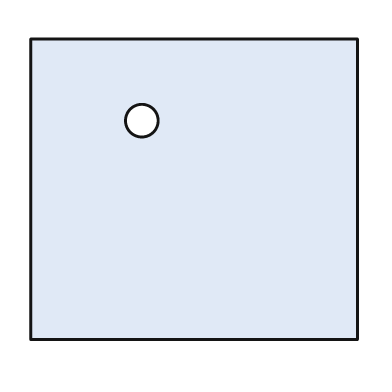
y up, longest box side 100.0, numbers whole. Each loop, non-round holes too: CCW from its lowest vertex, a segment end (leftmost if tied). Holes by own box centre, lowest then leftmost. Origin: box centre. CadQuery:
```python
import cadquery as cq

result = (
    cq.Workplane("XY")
    .moveTo(-50.0, -46.0)
    .lineTo(50.0, -46.0)
    .lineTo(50.0, 46.0)
    .lineTo(-50.0, 46.0)
    .close()
    .moveTo(-16.0, 21.0)
    .circle(5.0)
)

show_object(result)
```